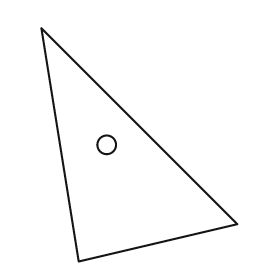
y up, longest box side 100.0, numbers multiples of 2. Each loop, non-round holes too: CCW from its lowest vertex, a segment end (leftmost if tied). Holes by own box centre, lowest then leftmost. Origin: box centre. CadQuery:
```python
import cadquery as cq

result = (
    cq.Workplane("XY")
    .moveTo(-26.0, -50.0)
    .lineTo(42.0, -34.0)
    .lineTo(-42.0, 50.0)
    .close()
    .moveTo(-14.0, 0.0)
    .circle(4.0)
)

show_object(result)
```